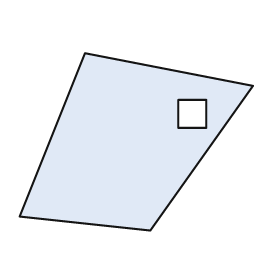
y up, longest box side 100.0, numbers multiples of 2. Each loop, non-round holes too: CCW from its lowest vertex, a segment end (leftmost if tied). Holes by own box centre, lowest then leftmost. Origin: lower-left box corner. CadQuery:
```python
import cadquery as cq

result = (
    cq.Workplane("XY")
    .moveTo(56.0, 0.0)
    .lineTo(100.0, 62.0)
    .lineTo(28.0, 76.0)
    .lineTo(0.0, 6.0)
    .close()
    .moveTo(68.0, 44.0)
    .lineTo(80.0, 44.0)
    .lineTo(80.0, 56.0)
    .lineTo(68.0, 56.0)
    .close()
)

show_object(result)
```